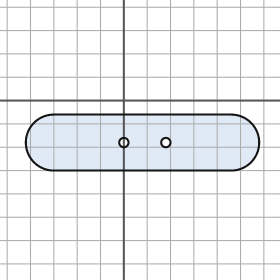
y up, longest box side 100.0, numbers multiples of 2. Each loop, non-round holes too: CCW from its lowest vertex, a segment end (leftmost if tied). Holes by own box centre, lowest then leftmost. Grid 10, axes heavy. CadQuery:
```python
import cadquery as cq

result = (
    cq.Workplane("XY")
    .moveTo(-30.0, -30.0)
    .lineTo(46.0, -30.0)
    .threePointArc((58.0, -18.0), (46.0, -6.0))
    .lineTo(-30.0, -6.0)
    .threePointArc((-42.0, -18.0), (-30.0, -30.0))
    .close()
    .moveTo(0.0, -18.0)
    .circle(2.0)
    .moveTo(18.0, -18.0)
    .circle(2.0)
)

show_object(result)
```